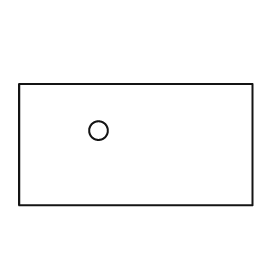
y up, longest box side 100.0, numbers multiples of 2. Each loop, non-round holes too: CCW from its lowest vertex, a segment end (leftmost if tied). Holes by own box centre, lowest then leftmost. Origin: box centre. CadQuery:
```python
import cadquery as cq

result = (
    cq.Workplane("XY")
    .moveTo(-50.0, -26.0)
    .lineTo(50.0, -26.0)
    .lineTo(50.0, 26.0)
    .lineTo(-50.0, 26.0)
    .close()
    .moveTo(-16.0, 6.0)
    .circle(4.0)
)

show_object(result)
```